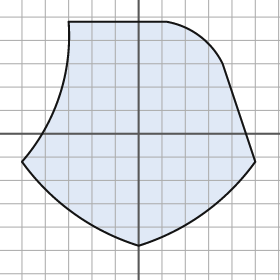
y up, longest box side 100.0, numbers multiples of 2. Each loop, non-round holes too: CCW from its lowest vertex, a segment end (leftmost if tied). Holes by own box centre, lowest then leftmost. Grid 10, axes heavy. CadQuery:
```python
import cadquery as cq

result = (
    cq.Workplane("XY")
    .moveTo(0.0, -48.0)
    .threePointArc((28.0, -34.0), (50.0, -12.0))
    .lineTo(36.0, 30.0)
    .threePointArc((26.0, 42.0), (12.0, 48.0))
    .lineTo(-30.0, 48.0)
    .threePointArc((-34.0, 16.0), (-50.0, -12.0))
    .threePointArc((-28.0, -34.0), (0.0, -48.0))
    .close()
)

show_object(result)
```